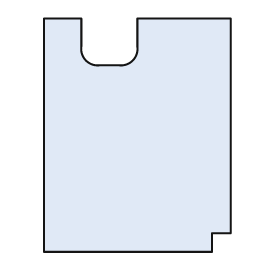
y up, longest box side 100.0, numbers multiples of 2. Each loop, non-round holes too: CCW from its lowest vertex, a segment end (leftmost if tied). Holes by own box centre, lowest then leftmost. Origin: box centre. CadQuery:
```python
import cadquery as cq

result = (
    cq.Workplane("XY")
    .moveTo(-40.0, -50.0)
    .lineTo(32.0, -50.0)
    .lineTo(32.0, -42.0)
    .lineTo(40.0, -42.0)
    .lineTo(40.0, 50.0)
    .lineTo(0.0, 50.0)
    .lineTo(0.0, 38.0)
    .threePointArc((-2.0, 32.0), (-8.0, 30.0))
    .lineTo(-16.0, 30.0)
    .threePointArc((-22.0, 32.0), (-24.0, 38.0))
    .lineTo(-24.0, 50.0)
    .lineTo(-40.0, 50.0)
    .close()
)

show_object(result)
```